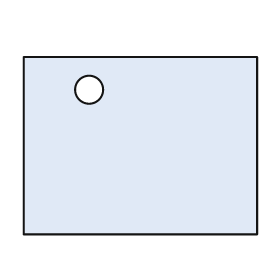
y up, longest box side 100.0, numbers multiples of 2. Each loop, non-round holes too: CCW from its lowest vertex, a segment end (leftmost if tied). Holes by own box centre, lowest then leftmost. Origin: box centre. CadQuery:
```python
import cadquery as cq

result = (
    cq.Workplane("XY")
    .moveTo(-50.0, -38.0)
    .lineTo(50.0, -38.0)
    .lineTo(50.0, 38.0)
    .lineTo(-50.0, 38.0)
    .close()
    .moveTo(-22.0, 24.0)
    .circle(6.0)
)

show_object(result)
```